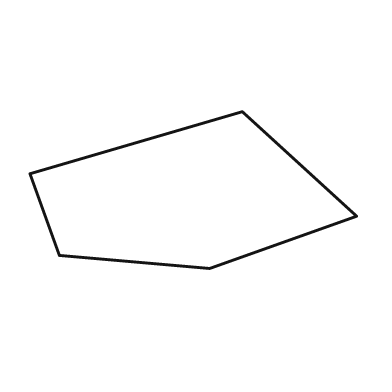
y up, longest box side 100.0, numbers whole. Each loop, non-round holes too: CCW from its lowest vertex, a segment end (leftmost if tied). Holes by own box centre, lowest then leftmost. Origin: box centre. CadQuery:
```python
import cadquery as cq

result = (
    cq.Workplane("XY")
    .moveTo(5.0, -24.0)
    .lineTo(50.0, -8.0)
    .lineTo(15.0, 24.0)
    .lineTo(-50.0, 5.0)
    .lineTo(-41.0, -20.0)
    .close()
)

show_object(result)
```